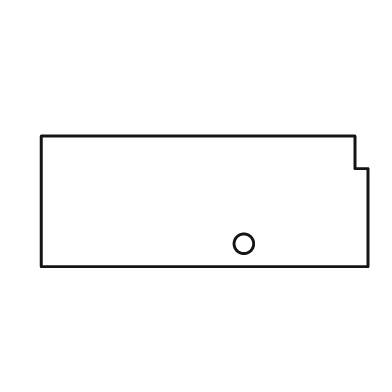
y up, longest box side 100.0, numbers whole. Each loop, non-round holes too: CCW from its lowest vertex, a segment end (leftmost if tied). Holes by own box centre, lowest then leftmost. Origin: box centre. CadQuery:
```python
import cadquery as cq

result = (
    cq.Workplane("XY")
    .moveTo(-50.0, -20.0)
    .lineTo(50.0, -20.0)
    .lineTo(50.0, 10.0)
    .lineTo(46.0, 10.0)
    .lineTo(46.0, 20.0)
    .lineTo(-50.0, 20.0)
    .close()
    .moveTo(12.0, -13.0)
    .circle(3.0)
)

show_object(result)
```